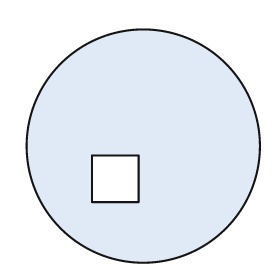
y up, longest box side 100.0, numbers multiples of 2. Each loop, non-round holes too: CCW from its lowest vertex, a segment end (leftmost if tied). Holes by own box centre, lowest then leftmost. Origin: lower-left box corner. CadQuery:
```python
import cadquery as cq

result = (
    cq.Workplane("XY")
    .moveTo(50.0, 50.0)
    .circle(50.0)
    .moveTo(28.0, 26.0)
    .lineTo(48.0, 26.0)
    .lineTo(48.0, 46.0)
    .lineTo(28.0, 46.0)
    .close()
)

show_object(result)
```